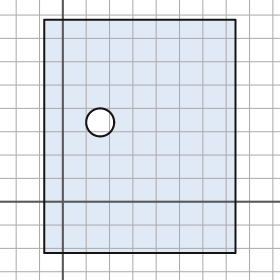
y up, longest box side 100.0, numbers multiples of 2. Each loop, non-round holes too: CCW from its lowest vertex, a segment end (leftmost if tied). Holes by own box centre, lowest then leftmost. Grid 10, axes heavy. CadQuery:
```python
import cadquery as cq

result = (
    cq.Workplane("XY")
    .moveTo(-8.0, -22.0)
    .lineTo(74.0, -22.0)
    .lineTo(74.0, 78.0)
    .lineTo(-8.0, 78.0)
    .close()
    .moveTo(16.0, 34.0)
    .circle(6.0)
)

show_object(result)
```